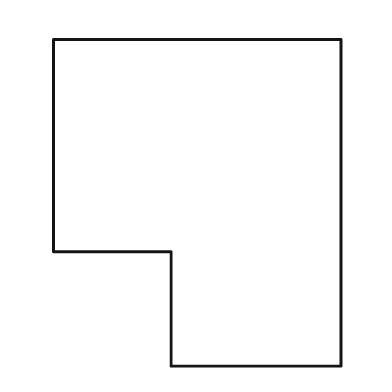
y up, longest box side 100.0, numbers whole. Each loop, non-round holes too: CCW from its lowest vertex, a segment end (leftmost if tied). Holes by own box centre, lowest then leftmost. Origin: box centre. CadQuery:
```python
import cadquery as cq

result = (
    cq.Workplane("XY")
    .moveTo(-8.0, -50.0)
    .lineTo(44.0, -50.0)
    .lineTo(44.0, 50.0)
    .lineTo(-44.0, 50.0)
    .lineTo(-44.0, -15.0)
    .lineTo(-8.0, -15.0)
    .close()
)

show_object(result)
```